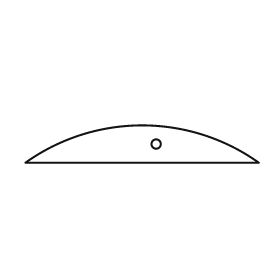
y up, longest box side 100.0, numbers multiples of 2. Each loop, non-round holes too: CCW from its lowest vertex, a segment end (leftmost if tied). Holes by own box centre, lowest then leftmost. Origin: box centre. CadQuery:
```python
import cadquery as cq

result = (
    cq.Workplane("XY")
    .moveTo(-50.0, -8.0)
    .lineTo(50.0, -8.0)
    .threePointArc((0.0, 8.0), (-50.0, -8.0))
    .close()
    .moveTo(6.0, 0.0)
    .circle(2.0)
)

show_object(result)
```